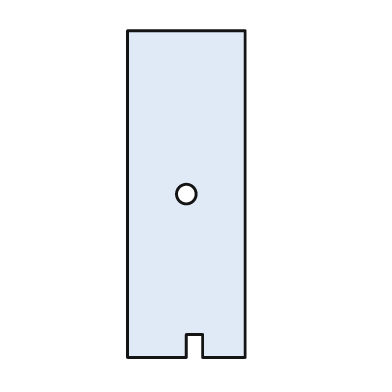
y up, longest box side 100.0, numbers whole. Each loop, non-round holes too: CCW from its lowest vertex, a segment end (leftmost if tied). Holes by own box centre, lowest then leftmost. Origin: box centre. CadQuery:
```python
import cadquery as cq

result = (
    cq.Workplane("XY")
    .moveTo(-18.0, -50.0)
    .lineTo(0.0, -50.0)
    .lineTo(0.0, -43.0)
    .lineTo(5.0, -43.0)
    .lineTo(5.0, -50.0)
    .lineTo(18.0, -50.0)
    .lineTo(18.0, 50.0)
    .lineTo(-18.0, 50.0)
    .close()
    .moveTo(0.0, 0.0)
    .circle(3.0)
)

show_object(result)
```